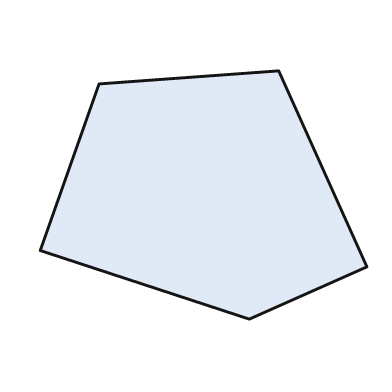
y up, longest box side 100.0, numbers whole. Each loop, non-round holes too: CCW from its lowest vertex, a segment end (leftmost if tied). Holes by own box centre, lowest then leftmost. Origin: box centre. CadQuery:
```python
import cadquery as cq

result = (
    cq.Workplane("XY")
    .moveTo(14.0, -38.0)
    .lineTo(50.0, -22.0)
    .lineTo(23.0, 38.0)
    .lineTo(-32.0, 34.0)
    .lineTo(-50.0, -17.0)
    .close()
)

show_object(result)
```